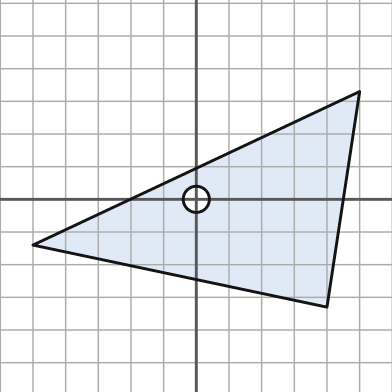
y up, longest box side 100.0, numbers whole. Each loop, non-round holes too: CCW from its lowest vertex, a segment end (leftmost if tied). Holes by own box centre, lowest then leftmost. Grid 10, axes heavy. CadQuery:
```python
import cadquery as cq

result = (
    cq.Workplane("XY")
    .moveTo(40.0, -33.0)
    .lineTo(50.0, 33.0)
    .lineTo(-50.0, -14.0)
    .close()
    .moveTo(0.0, 0.0)
    .circle(4.0)
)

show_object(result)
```